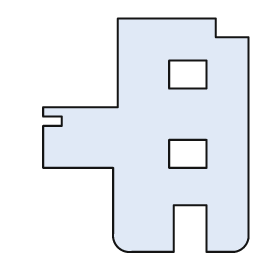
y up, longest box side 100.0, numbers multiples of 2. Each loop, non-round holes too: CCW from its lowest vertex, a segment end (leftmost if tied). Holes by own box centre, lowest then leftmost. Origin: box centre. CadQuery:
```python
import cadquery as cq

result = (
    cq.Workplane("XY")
    .moveTo(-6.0, -50.0)
    .lineTo(12.0, -50.0)
    .lineTo(12.0, -30.0)
    .lineTo(26.0, -30.0)
    .lineTo(26.0, -50.0)
    .lineTo(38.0, -50.0)
    .threePointArc((42.0, -48.0), (44.0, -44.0))
    .lineTo(44.0, 42.0)
    .lineTo(30.0, 42.0)
    .lineTo(30.0, 50.0)
    .lineTo(-12.0, 50.0)
    .lineTo(-12.0, 12.0)
    .lineTo(-44.0, 12.0)
    .lineTo(-44.0, 8.0)
    .lineTo(-36.0, 8.0)
    .lineTo(-36.0, 4.0)
    .lineTo(-44.0, 4.0)
    .lineTo(-44.0, -14.0)
    .lineTo(-14.0, -14.0)
    .lineTo(-14.0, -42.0)
    .threePointArc((-12.0, -48.0), (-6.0, -50.0))
    .close()
    .moveTo(10.0, -14.0)
    .lineTo(26.0, -14.0)
    .lineTo(26.0, -2.0)
    .lineTo(10.0, -2.0)
    .close()
    .moveTo(10.0, 20.0)
    .lineTo(26.0, 20.0)
    .lineTo(26.0, 32.0)
    .lineTo(10.0, 32.0)
    .close()
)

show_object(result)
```